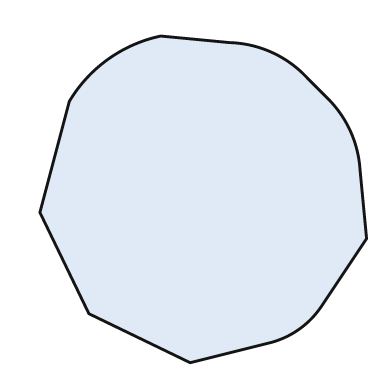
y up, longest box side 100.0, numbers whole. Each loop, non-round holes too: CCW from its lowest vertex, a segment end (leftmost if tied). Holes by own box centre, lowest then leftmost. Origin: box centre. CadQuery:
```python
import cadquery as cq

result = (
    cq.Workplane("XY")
    .moveTo(-4.0, -50.0)
    .lineTo(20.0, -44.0)
    .threePointArc((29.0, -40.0), (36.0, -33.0))
    .lineTo(50.0, -12.0)
    .lineTo(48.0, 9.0)
    .threePointArc((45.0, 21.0), (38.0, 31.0))
    .lineTo(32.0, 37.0)
    .threePointArc((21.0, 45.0), (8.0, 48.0))
    .lineTo(-13.0, 50.0)
    .threePointArc((-29.0, 43.0), (-41.0, 30.0))
    .lineTo(-50.0, -4.0)
    .lineTo(-35.0, -35.0)
    .close()
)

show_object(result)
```